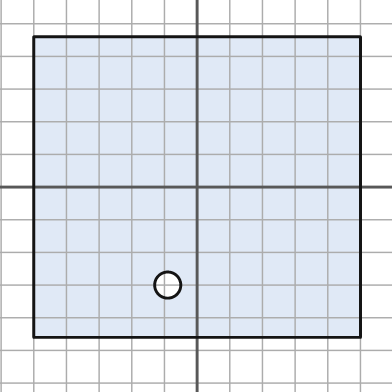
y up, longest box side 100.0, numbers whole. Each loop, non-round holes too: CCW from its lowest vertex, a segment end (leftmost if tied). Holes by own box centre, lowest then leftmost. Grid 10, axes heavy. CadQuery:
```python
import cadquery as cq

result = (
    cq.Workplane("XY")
    .moveTo(-50.0, -46.0)
    .lineTo(50.0, -46.0)
    .lineTo(50.0, 46.0)
    .lineTo(-50.0, 46.0)
    .close()
    .moveTo(-9.0, -30.0)
    .circle(4.0)
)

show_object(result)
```